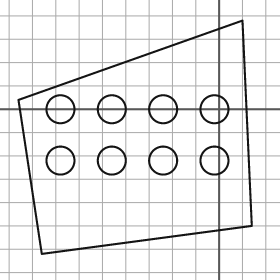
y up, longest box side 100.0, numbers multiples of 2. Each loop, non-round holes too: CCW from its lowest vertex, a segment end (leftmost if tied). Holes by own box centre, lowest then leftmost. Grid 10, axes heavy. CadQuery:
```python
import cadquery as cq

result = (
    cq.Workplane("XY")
    .moveTo(-76.0, -62.0)
    .lineTo(14.0, -50.0)
    .lineTo(10.0, 38.0)
    .lineTo(-86.0, 4.0)
    .close()
    .moveTo(-68.0, -22.0)
    .circle(6.0)
    .moveTo(-46.0, -22.0)
    .circle(6.0)
    .moveTo(-24.0, -22.0)
    .circle(6.0)
    .moveTo(-2.0, -22.0)
    .circle(6.0)
    .moveTo(-68.0, 0.0)
    .circle(6.0)
    .moveTo(-46.0, 0.0)
    .circle(6.0)
    .moveTo(-24.0, 0.0)
    .circle(6.0)
    .moveTo(-2.0, 0.0)
    .circle(6.0)
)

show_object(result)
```